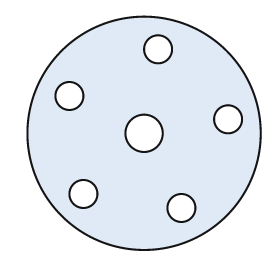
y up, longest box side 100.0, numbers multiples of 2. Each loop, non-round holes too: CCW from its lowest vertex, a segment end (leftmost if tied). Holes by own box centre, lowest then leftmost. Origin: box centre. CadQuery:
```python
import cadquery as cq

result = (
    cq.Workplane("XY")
    .moveTo(0.0, 0.0)
    .circle(50.0)
    .moveTo(16.0, -32.0)
    .circle(6.0)
    .moveTo(-26.0, -26.0)
    .circle(6.0)
    .moveTo(0.0, 0.0)
    .circle(8.0)
    .moveTo(36.0, 6.0)
    .circle(6.0)
    .moveTo(-32.0, 16.0)
    .circle(6.0)
    .moveTo(6.0, 36.0)
    .circle(6.0)
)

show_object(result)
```